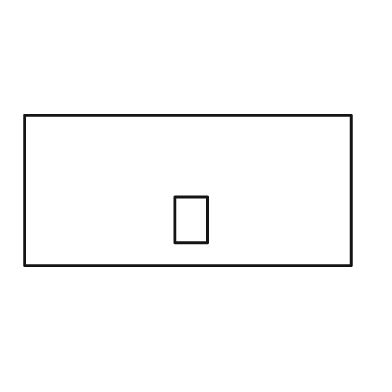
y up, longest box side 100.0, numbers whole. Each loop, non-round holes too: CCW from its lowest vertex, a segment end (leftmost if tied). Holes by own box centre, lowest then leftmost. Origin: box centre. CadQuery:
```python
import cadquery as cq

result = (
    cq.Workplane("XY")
    .moveTo(-50.0, -23.0)
    .lineTo(50.0, -23.0)
    .lineTo(50.0, 23.0)
    .lineTo(-50.0, 23.0)
    .close()
    .moveTo(-4.0, -16.0)
    .lineTo(6.0, -16.0)
    .lineTo(6.0, -2.0)
    .lineTo(-4.0, -2.0)
    .close()
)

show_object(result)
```